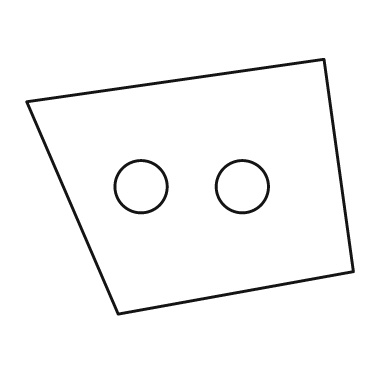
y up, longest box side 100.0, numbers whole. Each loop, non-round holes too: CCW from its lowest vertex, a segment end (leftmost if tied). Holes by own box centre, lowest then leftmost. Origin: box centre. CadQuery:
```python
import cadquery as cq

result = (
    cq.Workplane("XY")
    .moveTo(-22.0, -39.0)
    .lineTo(50.0, -26.0)
    .lineTo(41.0, 39.0)
    .lineTo(-50.0, 26.0)
    .close()
    .moveTo(-15.0, 0.0)
    .circle(8.0)
    .moveTo(16.0, 0.0)
    .circle(8.0)
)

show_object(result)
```